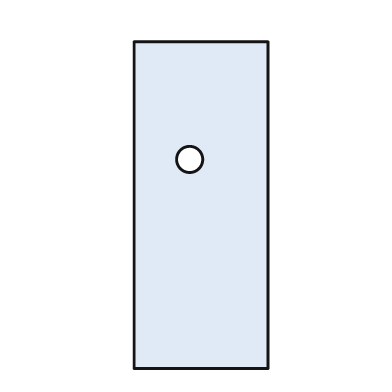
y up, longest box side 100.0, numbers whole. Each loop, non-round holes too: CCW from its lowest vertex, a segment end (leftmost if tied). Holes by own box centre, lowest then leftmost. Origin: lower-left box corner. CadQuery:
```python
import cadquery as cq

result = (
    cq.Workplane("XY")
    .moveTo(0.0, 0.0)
    .lineTo(41.0, 0.0)
    .lineTo(41.0, 100.0)
    .lineTo(0.0, 100.0)
    .close()
    .moveTo(17.0, 64.0)
    .circle(4.0)
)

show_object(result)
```